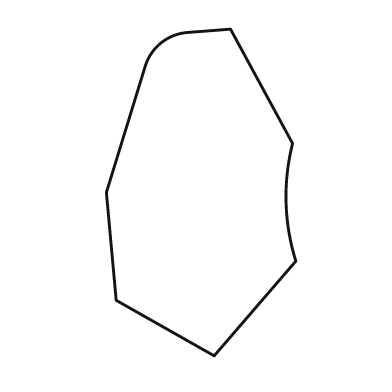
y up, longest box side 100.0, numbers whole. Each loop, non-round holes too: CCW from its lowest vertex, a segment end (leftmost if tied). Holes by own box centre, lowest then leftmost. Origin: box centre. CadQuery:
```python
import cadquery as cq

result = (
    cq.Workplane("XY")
    .moveTo(4.0, -50.0)
    .lineTo(29.0, -21.0)
    .threePointArc((26.0, -3.0), (28.0, 15.0))
    .lineTo(9.0, 50.0)
    .lineTo(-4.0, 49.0)
    .threePointArc((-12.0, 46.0), (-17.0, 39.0))
    .lineTo(-29.0, 0.0)
    .lineTo(-26.0, -33.0)
    .close()
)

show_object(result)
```